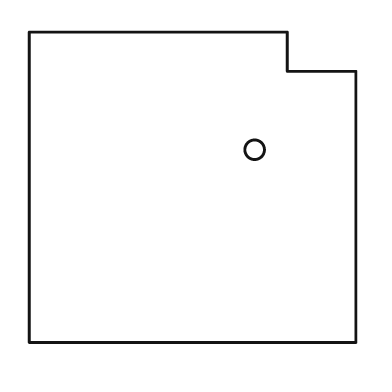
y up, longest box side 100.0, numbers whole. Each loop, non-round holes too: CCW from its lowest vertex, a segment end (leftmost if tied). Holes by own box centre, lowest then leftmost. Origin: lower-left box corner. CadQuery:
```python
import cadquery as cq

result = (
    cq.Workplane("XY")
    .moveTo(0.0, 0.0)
    .lineTo(100.0, 0.0)
    .lineTo(100.0, 83.0)
    .lineTo(79.0, 83.0)
    .lineTo(79.0, 95.0)
    .lineTo(0.0, 95.0)
    .close()
    .moveTo(69.0, 59.0)
    .circle(3.0)
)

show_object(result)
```